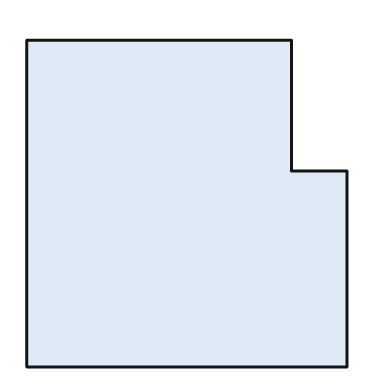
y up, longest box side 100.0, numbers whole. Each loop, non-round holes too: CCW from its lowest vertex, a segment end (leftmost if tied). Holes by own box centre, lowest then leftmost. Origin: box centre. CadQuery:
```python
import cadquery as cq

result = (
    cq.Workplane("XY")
    .moveTo(-49.0, -50.0)
    .lineTo(49.0, -50.0)
    .lineTo(49.0, 10.0)
    .lineTo(32.0, 10.0)
    .lineTo(32.0, 50.0)
    .lineTo(-49.0, 50.0)
    .close()
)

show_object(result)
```